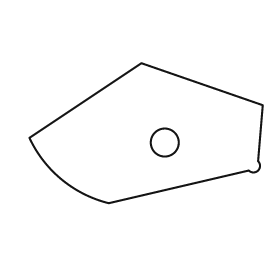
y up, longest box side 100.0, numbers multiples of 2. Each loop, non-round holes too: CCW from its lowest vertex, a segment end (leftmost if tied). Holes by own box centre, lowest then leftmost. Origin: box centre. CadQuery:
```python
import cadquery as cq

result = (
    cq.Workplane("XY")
    .moveTo(-16.0, -30.0)
    .lineTo(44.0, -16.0)
    .threePointArc((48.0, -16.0), (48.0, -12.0))
    .lineTo(50.0, 12.0)
    .lineTo(-2.0, 30.0)
    .lineTo(-50.0, -2.0)
    .threePointArc((-36.0, -20.0), (-16.0, -30.0))
    .close()
    .moveTo(8.0, -4.0)
    .circle(6.0)
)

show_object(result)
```